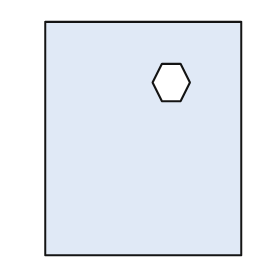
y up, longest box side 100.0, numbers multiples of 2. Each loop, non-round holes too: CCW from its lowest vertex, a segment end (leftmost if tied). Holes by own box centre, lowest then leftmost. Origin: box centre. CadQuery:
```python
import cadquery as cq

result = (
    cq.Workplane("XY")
    .moveTo(-42.0, -50.0)
    .lineTo(42.0, -50.0)
    .lineTo(42.0, 50.0)
    .lineTo(-42.0, 50.0)
    .close()
    .moveTo(8.0, 16.0)
    .lineTo(16.0, 16.0)
    .lineTo(20.0, 24.0)
    .lineTo(16.0, 32.0)
    .lineTo(8.0, 32.0)
    .lineTo(4.0, 24.0)
    .close()
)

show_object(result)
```